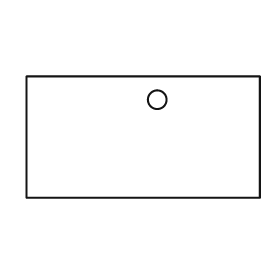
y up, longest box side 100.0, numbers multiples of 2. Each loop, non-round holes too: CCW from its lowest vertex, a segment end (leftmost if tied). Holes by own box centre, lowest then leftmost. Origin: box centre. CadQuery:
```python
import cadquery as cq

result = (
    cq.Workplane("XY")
    .moveTo(-50.0, -26.0)
    .lineTo(50.0, -26.0)
    .lineTo(50.0, 26.0)
    .lineTo(-50.0, 26.0)
    .close()
    .moveTo(6.0, 16.0)
    .circle(4.0)
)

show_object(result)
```